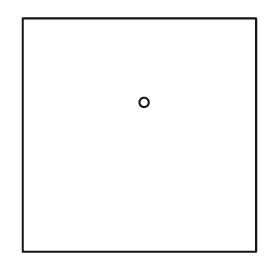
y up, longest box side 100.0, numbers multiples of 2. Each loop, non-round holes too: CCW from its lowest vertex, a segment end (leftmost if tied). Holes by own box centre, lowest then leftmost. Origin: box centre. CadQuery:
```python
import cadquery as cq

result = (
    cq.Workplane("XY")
    .moveTo(-50.0, -50.0)
    .lineTo(50.0, -50.0)
    .lineTo(50.0, 50.0)
    .lineTo(-50.0, 50.0)
    .close()
    .moveTo(2.0, 14.0)
    .circle(2.0)
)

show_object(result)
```